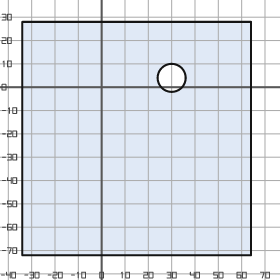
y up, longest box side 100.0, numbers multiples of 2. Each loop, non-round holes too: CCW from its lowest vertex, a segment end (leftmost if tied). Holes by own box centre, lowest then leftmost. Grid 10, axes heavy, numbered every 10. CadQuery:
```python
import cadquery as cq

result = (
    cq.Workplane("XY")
    .moveTo(-34.0, -72.0)
    .lineTo(64.0, -72.0)
    .lineTo(64.0, 28.0)
    .lineTo(-34.0, 28.0)
    .close()
    .moveTo(30.0, 4.0)
    .circle(6.0)
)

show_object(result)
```